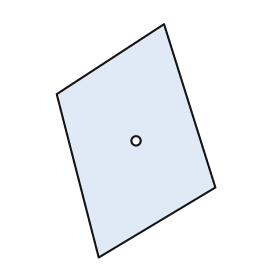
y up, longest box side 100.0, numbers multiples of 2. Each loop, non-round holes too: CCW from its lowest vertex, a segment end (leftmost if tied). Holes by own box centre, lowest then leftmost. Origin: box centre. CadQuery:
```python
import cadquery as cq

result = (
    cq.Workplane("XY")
    .moveTo(-16.0, -50.0)
    .lineTo(34.0, -20.0)
    .lineTo(12.0, 50.0)
    .lineTo(-34.0, 20.0)
    .close()
    .moveTo(0.0, 0.0)
    .circle(2.0)
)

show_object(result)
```